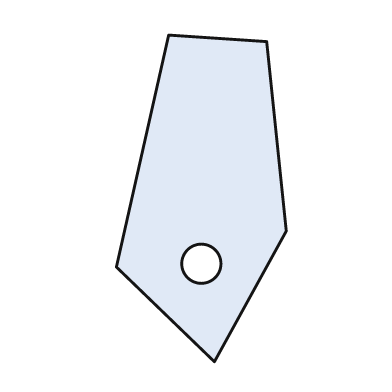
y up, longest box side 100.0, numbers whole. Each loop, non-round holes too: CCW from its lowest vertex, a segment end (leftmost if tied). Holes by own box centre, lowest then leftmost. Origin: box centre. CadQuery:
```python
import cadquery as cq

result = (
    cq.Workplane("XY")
    .moveTo(4.0, -50.0)
    .lineTo(26.0, -10.0)
    .lineTo(20.0, 48.0)
    .lineTo(-10.0, 50.0)
    .lineTo(-26.0, -21.0)
    .close()
    .moveTo(0.0, -20.0)
    .circle(6.0)
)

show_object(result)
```